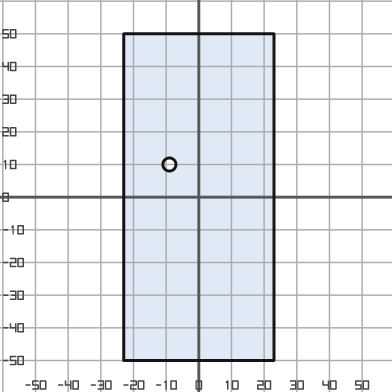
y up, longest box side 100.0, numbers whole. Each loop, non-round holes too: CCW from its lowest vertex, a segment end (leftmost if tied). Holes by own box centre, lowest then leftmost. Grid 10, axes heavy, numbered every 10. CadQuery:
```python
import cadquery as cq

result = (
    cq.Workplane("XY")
    .moveTo(-23.0, -50.0)
    .lineTo(23.0, -50.0)
    .lineTo(23.0, 50.0)
    .lineTo(-23.0, 50.0)
    .close()
    .moveTo(-9.0, 10.0)
    .circle(2.0)
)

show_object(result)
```